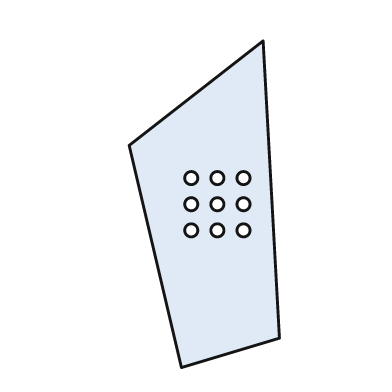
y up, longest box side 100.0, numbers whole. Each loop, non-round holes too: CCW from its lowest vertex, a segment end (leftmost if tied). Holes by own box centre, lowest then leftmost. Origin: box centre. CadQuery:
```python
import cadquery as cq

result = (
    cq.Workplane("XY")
    .moveTo(-7.0, -50.0)
    .lineTo(23.0, -41.0)
    .lineTo(18.0, 50.0)
    .lineTo(-23.0, 18.0)
    .close()
    .moveTo(-4.0, -8.0)
    .circle(2.0)
    .moveTo(4.0, -8.0)
    .circle(2.0)
    .moveTo(12.0, -8.0)
    .circle(2.0)
    .moveTo(-4.0, 0.0)
    .circle(2.0)
    .moveTo(4.0, 0.0)
    .circle(2.0)
    .moveTo(12.0, 0.0)
    .circle(2.0)
    .moveTo(-4.0, 8.0)
    .circle(2.0)
    .moveTo(4.0, 8.0)
    .circle(2.0)
    .moveTo(12.0, 8.0)
    .circle(2.0)
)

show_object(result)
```